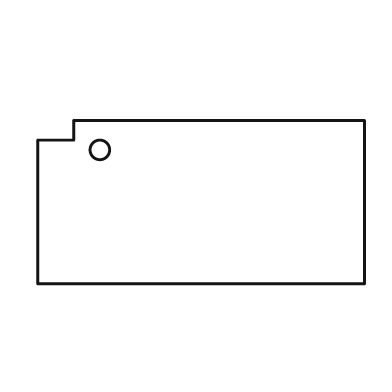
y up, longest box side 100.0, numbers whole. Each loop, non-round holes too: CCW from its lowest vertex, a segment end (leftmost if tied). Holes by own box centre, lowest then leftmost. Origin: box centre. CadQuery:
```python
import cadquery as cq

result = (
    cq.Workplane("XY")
    .moveTo(-50.0, -25.0)
    .lineTo(50.0, -25.0)
    .lineTo(50.0, 25.0)
    .lineTo(-39.0, 25.0)
    .lineTo(-39.0, 19.0)
    .lineTo(-50.0, 19.0)
    .close()
    .moveTo(-31.0, 16.0)
    .circle(3.0)
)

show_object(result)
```